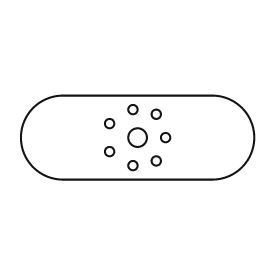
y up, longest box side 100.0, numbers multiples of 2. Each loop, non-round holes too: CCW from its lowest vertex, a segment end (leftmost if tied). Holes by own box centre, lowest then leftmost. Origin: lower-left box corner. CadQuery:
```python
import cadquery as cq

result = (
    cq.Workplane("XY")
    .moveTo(18.0, 0.0)
    .lineTo(82.0, 0.0)
    .threePointArc((100.0, 18.0), (82.0, 36.0))
    .lineTo(18.0, 36.0)
    .threePointArc((0.0, 18.0), (18.0, 0.0))
    .close()
    .moveTo(48.0, 6.0)
    .circle(2.0)
    .moveTo(58.0, 8.0)
    .circle(2.0)
    .moveTo(38.0, 12.0)
    .circle(2.0)
    .moveTo(50.0, 18.0)
    .circle(4.0)
    .moveTo(62.0, 18.0)
    .circle(2.0)
    .moveTo(38.0, 24.0)
    .circle(2.0)
    .moveTo(58.0, 28.0)
    .circle(2.0)
    .moveTo(48.0, 30.0)
    .circle(2.0)
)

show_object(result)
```